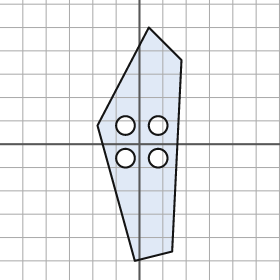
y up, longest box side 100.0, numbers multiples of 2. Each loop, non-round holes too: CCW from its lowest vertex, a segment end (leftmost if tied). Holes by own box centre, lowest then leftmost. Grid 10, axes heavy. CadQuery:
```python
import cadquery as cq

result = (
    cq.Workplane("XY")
    .moveTo(-2.0, -50.0)
    .lineTo(14.0, -46.0)
    .lineTo(18.0, 36.0)
    .lineTo(4.0, 50.0)
    .lineTo(-18.0, 8.0)
    .close()
    .moveTo(-6.0, -6.0)
    .circle(4.0)
    .moveTo(8.0, -6.0)
    .circle(4.0)
    .moveTo(-6.0, 8.0)
    .circle(4.0)
    .moveTo(8.0, 8.0)
    .circle(4.0)
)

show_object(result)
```